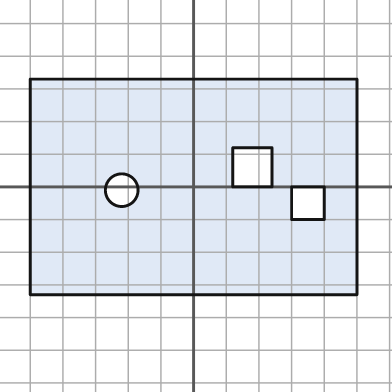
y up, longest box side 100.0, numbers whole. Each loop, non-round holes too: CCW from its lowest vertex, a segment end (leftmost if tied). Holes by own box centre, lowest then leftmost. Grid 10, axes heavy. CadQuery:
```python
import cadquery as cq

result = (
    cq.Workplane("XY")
    .moveTo(-50.0, -33.0)
    .lineTo(50.0, -33.0)
    .lineTo(50.0, 33.0)
    .lineTo(-50.0, 33.0)
    .close()
    .moveTo(30.0, -10.0)
    .lineTo(40.0, -10.0)
    .lineTo(40.0, 0.0)
    .lineTo(30.0, 0.0)
    .close()
    .moveTo(-22.0, -1.0)
    .circle(5.0)
    .moveTo(12.0, 0.0)
    .lineTo(24.0, 0.0)
    .lineTo(24.0, 12.0)
    .lineTo(12.0, 12.0)
    .close()
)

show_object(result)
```